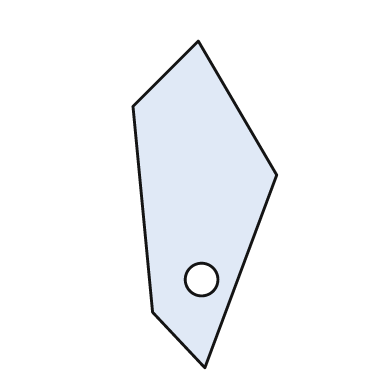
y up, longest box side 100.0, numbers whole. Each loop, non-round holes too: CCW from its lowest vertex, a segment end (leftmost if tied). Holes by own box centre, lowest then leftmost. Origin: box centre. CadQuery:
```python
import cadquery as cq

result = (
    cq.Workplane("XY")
    .moveTo(0.0, -50.0)
    .lineTo(22.0, 9.0)
    .lineTo(-2.0, 50.0)
    .lineTo(-22.0, 30.0)
    .lineTo(-16.0, -33.0)
    .close()
    .moveTo(-1.0, -23.0)
    .circle(5.0)
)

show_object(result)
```